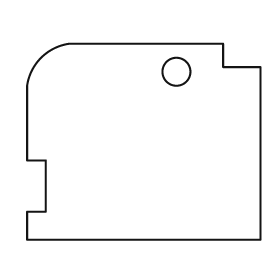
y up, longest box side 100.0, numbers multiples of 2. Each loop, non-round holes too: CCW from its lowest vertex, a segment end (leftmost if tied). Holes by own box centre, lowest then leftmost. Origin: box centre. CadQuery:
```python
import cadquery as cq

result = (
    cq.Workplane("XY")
    .moveTo(-50.0, -42.0)
    .lineTo(50.0, -42.0)
    .lineTo(50.0, 32.0)
    .lineTo(34.0, 32.0)
    .lineTo(34.0, 42.0)
    .lineTo(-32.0, 42.0)
    .threePointArc((-44.0, 36.0), (-50.0, 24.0))
    .lineTo(-50.0, -8.0)
    .lineTo(-42.0, -8.0)
    .lineTo(-42.0, -30.0)
    .lineTo(-50.0, -30.0)
    .close()
    .moveTo(14.0, 30.0)
    .circle(6.0)
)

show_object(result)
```